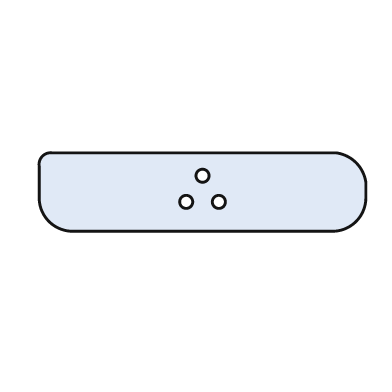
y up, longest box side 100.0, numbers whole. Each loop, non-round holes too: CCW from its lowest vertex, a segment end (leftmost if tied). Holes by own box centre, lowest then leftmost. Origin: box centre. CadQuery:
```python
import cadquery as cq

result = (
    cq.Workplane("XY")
    .moveTo(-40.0, -12.0)
    .lineTo(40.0, -12.0)
    .threePointArc((47.0, -9.0), (50.0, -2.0))
    .lineTo(50.0, 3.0)
    .threePointArc((47.0, 9.0), (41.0, 12.0))
    .lineTo(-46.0, 12.0)
    .threePointArc((-49.0, 11.0), (-50.0, 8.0))
    .lineTo(-50.0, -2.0)
    .threePointArc((-47.0, -9.0), (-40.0, -12.0))
    .close()
    .moveTo(-5.0, -3.0)
    .circle(2.0)
    .moveTo(5.0, -3.0)
    .circle(2.0)
    .moveTo(0.0, 5.0)
    .circle(2.0)
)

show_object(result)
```